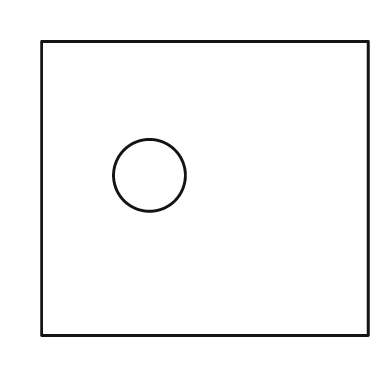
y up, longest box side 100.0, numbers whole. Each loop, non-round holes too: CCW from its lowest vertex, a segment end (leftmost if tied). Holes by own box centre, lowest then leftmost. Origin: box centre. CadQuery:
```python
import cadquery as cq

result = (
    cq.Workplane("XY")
    .moveTo(-50.0, -45.0)
    .lineTo(50.0, -45.0)
    .lineTo(50.0, 45.0)
    .lineTo(-50.0, 45.0)
    .close()
    .moveTo(-17.0, 4.0)
    .circle(11.0)
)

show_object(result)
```